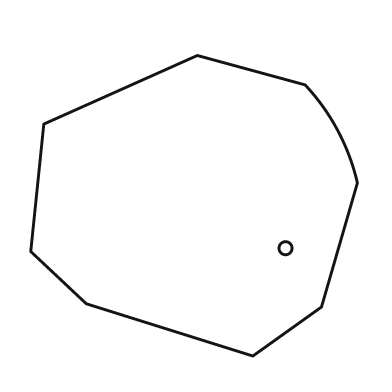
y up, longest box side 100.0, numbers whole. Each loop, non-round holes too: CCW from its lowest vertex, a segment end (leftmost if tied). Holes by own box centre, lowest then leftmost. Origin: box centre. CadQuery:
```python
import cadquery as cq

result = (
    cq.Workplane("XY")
    .moveTo(18.0, -46.0)
    .lineTo(39.0, -31.0)
    .lineTo(50.0, 7.0)
    .threePointArc((44.0, 23.0), (34.0, 37.0))
    .lineTo(1.0, 46.0)
    .lineTo(-46.0, 25.0)
    .lineTo(-50.0, -14.0)
    .lineTo(-33.0, -30.0)
    .close()
    .moveTo(28.0, -13.0)
    .circle(2.0)
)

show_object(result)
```